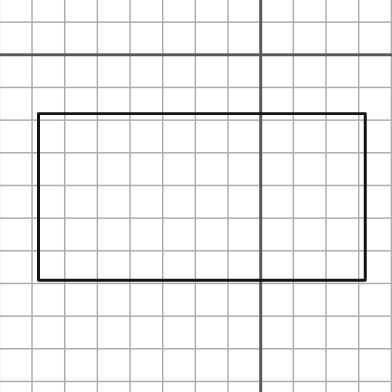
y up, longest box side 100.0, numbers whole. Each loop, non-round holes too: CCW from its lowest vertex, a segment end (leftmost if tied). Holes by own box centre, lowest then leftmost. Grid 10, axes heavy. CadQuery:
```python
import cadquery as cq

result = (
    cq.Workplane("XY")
    .moveTo(-68.0, -69.0)
    .lineTo(32.0, -69.0)
    .lineTo(32.0, -18.0)
    .lineTo(-68.0, -18.0)
    .close()
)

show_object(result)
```